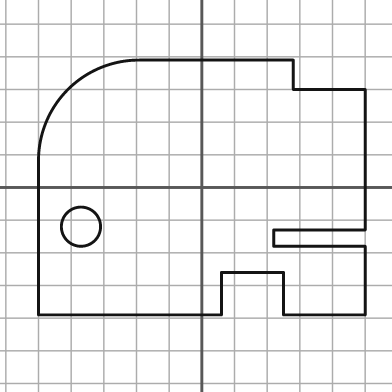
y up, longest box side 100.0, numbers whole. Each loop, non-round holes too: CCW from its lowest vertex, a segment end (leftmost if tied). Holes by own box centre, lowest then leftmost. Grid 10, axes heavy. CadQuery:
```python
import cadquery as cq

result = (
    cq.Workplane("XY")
    .moveTo(-50.0, -39.0)
    .lineTo(6.0, -39.0)
    .lineTo(6.0, -26.0)
    .lineTo(25.0, -26.0)
    .lineTo(25.0, -39.0)
    .lineTo(50.0, -39.0)
    .lineTo(50.0, -18.0)
    .lineTo(22.0, -18.0)
    .lineTo(22.0, -13.0)
    .lineTo(50.0, -13.0)
    .lineTo(50.0, 30.0)
    .lineTo(28.0, 30.0)
    .lineTo(28.0, 39.0)
    .lineTo(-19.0, 39.0)
    .threePointArc((-41.0, 30.0), (-50.0, 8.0))
    .close()
    .moveTo(-37.0, -12.0)
    .circle(6.0)
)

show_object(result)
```